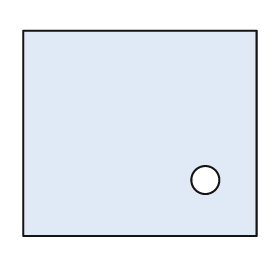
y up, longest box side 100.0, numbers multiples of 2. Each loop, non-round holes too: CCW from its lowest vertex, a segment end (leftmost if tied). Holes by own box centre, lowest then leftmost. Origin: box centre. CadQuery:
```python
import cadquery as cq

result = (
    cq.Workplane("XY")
    .moveTo(-50.0, -44.0)
    .lineTo(50.0, -44.0)
    .lineTo(50.0, 44.0)
    .lineTo(-50.0, 44.0)
    .close()
    .moveTo(28.0, -20.0)
    .circle(6.0)
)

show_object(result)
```